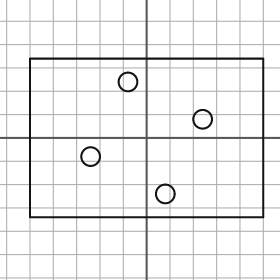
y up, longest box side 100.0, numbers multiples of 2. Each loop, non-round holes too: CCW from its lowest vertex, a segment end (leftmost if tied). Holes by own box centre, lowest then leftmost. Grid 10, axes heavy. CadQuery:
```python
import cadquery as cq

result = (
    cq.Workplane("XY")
    .moveTo(-50.0, -34.0)
    .lineTo(50.0, -34.0)
    .lineTo(50.0, 34.0)
    .lineTo(-50.0, 34.0)
    .close()
    .moveTo(8.0, -24.0)
    .circle(4.0)
    .moveTo(-24.0, -8.0)
    .circle(4.0)
    .moveTo(24.0, 8.0)
    .circle(4.0)
    .moveTo(-8.0, 24.0)
    .circle(4.0)
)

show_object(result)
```